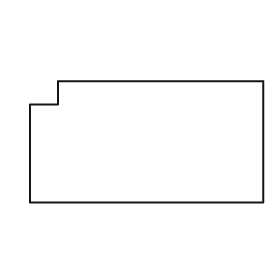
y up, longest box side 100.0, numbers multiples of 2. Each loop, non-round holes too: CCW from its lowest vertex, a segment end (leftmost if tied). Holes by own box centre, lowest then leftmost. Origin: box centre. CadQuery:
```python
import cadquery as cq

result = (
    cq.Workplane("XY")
    .moveTo(-50.0, -26.0)
    .lineTo(50.0, -26.0)
    .lineTo(50.0, 26.0)
    .lineTo(-38.0, 26.0)
    .lineTo(-38.0, 16.0)
    .lineTo(-50.0, 16.0)
    .close()
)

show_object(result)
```